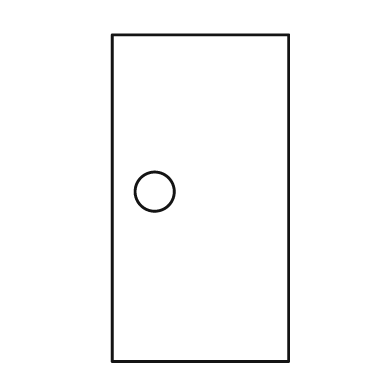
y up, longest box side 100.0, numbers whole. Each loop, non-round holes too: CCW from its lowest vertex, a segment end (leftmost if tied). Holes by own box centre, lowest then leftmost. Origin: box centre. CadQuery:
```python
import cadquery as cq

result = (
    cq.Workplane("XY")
    .moveTo(-27.0, -50.0)
    .lineTo(27.0, -50.0)
    .lineTo(27.0, 50.0)
    .lineTo(-27.0, 50.0)
    .close()
    .moveTo(-14.0, 2.0)
    .circle(6.0)
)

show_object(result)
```